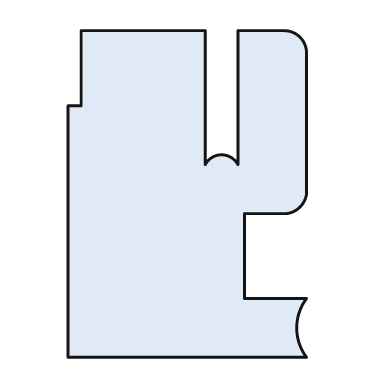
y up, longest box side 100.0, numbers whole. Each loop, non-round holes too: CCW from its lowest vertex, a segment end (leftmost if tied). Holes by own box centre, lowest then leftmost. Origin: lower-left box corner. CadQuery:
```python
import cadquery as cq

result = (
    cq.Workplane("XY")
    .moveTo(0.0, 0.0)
    .lineTo(73.0, 0.0)
    .threePointArc((70.0, 9.0), (73.0, 18.0))
    .lineTo(54.0, 18.0)
    .lineTo(54.0, 44.0)
    .lineTo(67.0, 44.0)
    .threePointArc((71.0, 46.0), (73.0, 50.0))
    .lineTo(73.0, 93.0)
    .threePointArc((71.0, 98.0), (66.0, 100.0))
    .lineTo(52.0, 100.0)
    .lineTo(52.0, 59.0)
    .threePointArc((47.0, 62.0), (42.0, 59.0))
    .lineTo(42.0, 100.0)
    .lineTo(4.0, 100.0)
    .lineTo(4.0, 77.0)
    .lineTo(0.0, 77.0)
    .close()
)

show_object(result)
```